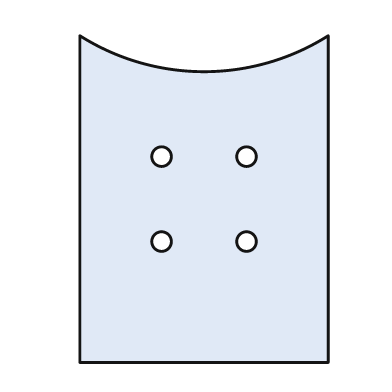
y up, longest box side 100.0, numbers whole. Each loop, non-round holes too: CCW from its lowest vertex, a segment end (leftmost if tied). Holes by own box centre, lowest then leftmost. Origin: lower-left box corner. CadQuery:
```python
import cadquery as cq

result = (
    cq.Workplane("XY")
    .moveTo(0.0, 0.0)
    .lineTo(76.0, 0.0)
    .lineTo(76.0, 100.0)
    .threePointArc((38.0, 89.0), (0.0, 100.0))
    .close()
    .moveTo(25.0, 37.0)
    .circle(3.0)
    .moveTo(51.0, 37.0)
    .circle(3.0)
    .moveTo(25.0, 63.0)
    .circle(3.0)
    .moveTo(51.0, 63.0)
    .circle(3.0)
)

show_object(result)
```